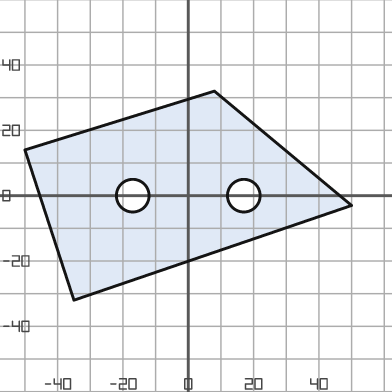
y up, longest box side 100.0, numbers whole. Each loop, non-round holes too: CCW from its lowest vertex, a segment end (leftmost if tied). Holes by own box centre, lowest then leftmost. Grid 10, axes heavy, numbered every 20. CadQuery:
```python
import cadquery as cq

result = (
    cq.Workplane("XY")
    .moveTo(-35.0, -32.0)
    .lineTo(50.0, -3.0)
    .lineTo(8.0, 32.0)
    .lineTo(-50.0, 14.0)
    .close()
    .moveTo(-17.0, 0.0)
    .circle(5.0)
    .moveTo(17.0, 0.0)
    .circle(5.0)
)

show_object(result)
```